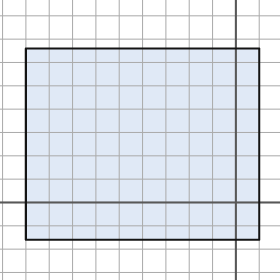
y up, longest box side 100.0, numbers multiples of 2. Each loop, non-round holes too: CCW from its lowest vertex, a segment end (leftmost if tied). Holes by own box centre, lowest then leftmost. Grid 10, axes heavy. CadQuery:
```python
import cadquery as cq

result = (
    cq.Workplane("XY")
    .moveTo(-90.0, -16.0)
    .lineTo(10.0, -16.0)
    .lineTo(10.0, 66.0)
    .lineTo(-90.0, 66.0)
    .close()
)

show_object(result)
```